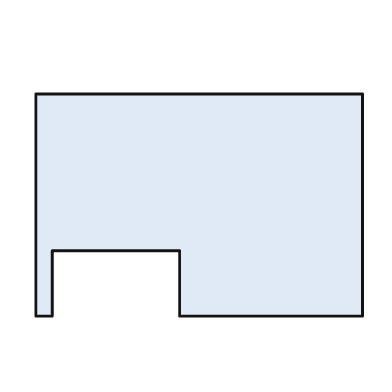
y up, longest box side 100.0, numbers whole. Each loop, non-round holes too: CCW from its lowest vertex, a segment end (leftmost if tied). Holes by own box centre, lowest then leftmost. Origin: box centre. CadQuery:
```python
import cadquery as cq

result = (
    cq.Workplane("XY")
    .moveTo(-50.0, -34.0)
    .lineTo(-45.0, -34.0)
    .lineTo(-45.0, -14.0)
    .lineTo(-6.0, -14.0)
    .lineTo(-6.0, -34.0)
    .lineTo(50.0, -34.0)
    .lineTo(50.0, 34.0)
    .lineTo(-50.0, 34.0)
    .close()
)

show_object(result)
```